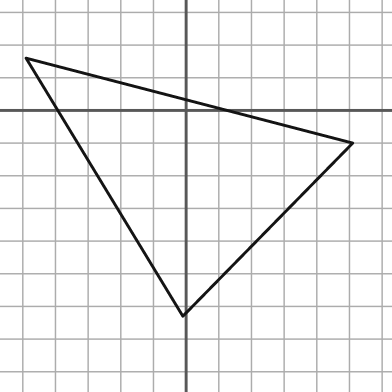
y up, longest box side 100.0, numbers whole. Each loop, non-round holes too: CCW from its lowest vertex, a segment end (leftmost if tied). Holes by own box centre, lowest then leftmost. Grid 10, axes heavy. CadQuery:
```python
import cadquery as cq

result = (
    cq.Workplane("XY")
    .moveTo(-1.0, -63.0)
    .lineTo(51.0, -10.0)
    .lineTo(-49.0, 16.0)
    .close()
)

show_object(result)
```